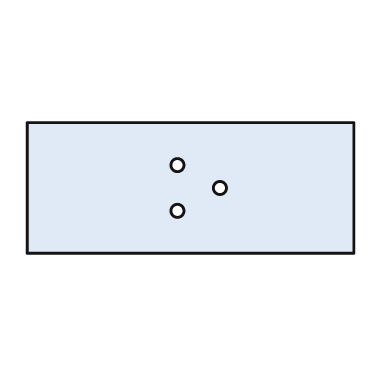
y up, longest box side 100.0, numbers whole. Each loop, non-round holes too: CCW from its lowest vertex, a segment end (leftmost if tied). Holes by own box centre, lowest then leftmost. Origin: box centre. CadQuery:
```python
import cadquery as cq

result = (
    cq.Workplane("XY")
    .moveTo(-50.0, -20.0)
    .lineTo(50.0, -20.0)
    .lineTo(50.0, 20.0)
    .lineTo(-50.0, 20.0)
    .close()
    .moveTo(-4.0, -7.0)
    .circle(2.0)
    .moveTo(9.0, 0.0)
    .circle(2.0)
    .moveTo(-4.0, 7.0)
    .circle(2.0)
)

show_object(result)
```